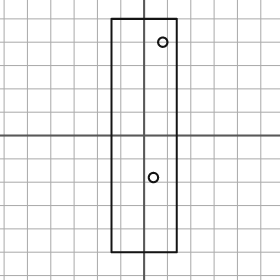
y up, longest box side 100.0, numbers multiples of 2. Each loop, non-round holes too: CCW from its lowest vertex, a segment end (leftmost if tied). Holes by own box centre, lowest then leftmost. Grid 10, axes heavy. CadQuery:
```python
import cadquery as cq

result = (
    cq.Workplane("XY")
    .moveTo(-14.0, -50.0)
    .lineTo(14.0, -50.0)
    .lineTo(14.0, 50.0)
    .lineTo(-14.0, 50.0)
    .close()
    .moveTo(4.0, -18.0)
    .circle(2.0)
    .moveTo(8.0, 40.0)
    .circle(2.0)
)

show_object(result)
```